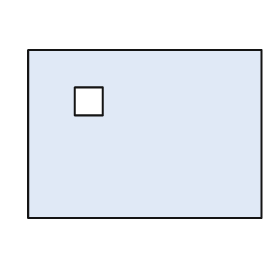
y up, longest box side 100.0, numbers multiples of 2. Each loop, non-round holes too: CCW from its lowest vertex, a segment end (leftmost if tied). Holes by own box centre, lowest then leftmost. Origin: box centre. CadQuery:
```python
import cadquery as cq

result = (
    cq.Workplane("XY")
    .moveTo(-50.0, -36.0)
    .lineTo(50.0, -36.0)
    .lineTo(50.0, 36.0)
    .lineTo(-50.0, 36.0)
    .close()
    .moveTo(-30.0, 8.0)
    .lineTo(-18.0, 8.0)
    .lineTo(-18.0, 20.0)
    .lineTo(-30.0, 20.0)
    .close()
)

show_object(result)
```